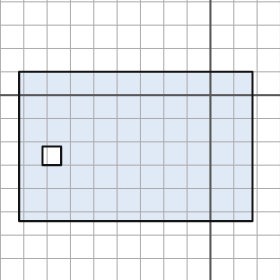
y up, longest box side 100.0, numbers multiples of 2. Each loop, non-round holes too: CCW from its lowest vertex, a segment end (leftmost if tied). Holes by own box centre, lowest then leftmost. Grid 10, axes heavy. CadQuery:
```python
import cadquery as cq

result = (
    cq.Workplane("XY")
    .moveTo(-82.0, -54.0)
    .lineTo(18.0, -54.0)
    .lineTo(18.0, 10.0)
    .lineTo(-82.0, 10.0)
    .close()
    .moveTo(-72.0, -30.0)
    .lineTo(-64.0, -30.0)
    .lineTo(-64.0, -22.0)
    .lineTo(-72.0, -22.0)
    .close()
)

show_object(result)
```